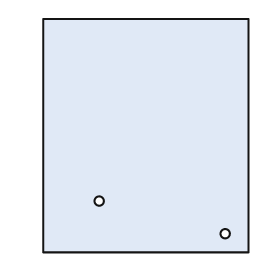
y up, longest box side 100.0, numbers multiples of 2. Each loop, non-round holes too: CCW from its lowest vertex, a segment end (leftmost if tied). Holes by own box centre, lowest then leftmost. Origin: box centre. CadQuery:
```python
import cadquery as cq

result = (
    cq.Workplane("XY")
    .moveTo(-44.0, -50.0)
    .lineTo(44.0, -50.0)
    .lineTo(44.0, 50.0)
    .lineTo(-44.0, 50.0)
    .close()
    .moveTo(34.0, -42.0)
    .circle(2.0)
    .moveTo(-20.0, -28.0)
    .circle(2.0)
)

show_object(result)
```